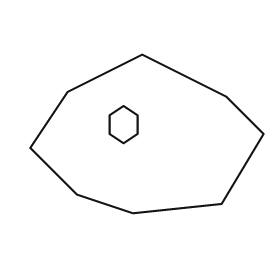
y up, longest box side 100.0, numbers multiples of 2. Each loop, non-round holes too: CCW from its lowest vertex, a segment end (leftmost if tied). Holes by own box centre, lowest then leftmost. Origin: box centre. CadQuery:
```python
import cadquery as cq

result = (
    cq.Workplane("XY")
    .moveTo(-6.0, -34.0)
    .lineTo(32.0, -30.0)
    .lineTo(50.0, 0.0)
    .lineTo(34.0, 16.0)
    .lineTo(-2.0, 34.0)
    .lineTo(-34.0, 18.0)
    .lineTo(-50.0, -6.0)
    .lineTo(-30.0, -26.0)
    .close()
    .moveTo(-10.0, -4.0)
    .lineTo(-4.0, 0.0)
    .lineTo(-4.0, 8.0)
    .lineTo(-10.0, 12.0)
    .lineTo(-16.0, 8.0)
    .lineTo(-16.0, 0.0)
    .close()
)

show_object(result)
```